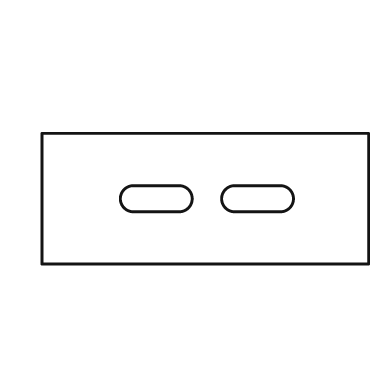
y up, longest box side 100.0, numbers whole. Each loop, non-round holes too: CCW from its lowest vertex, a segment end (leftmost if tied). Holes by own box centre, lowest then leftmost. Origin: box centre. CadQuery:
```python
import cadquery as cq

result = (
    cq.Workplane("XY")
    .moveTo(-50.0, -20.0)
    .lineTo(50.0, -20.0)
    .lineTo(50.0, 20.0)
    .lineTo(-50.0, 20.0)
    .close()
    .moveTo(-22.0, -4.0)
    .lineTo(-8.0, -4.0)
    .threePointArc((-4.0, 0.0), (-8.0, 4.0))
    .lineTo(-22.0, 4.0)
    .threePointArc((-26.0, 0.0), (-22.0, -4.0))
    .close()
    .moveTo(9.0, -4.0)
    .lineTo(23.0, -4.0)
    .threePointArc((27.0, 0.0), (23.0, 4.0))
    .lineTo(9.0, 4.0)
    .threePointArc((5.0, 0.0), (9.0, -4.0))
    .close()
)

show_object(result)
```